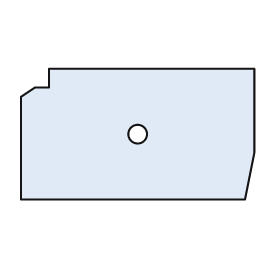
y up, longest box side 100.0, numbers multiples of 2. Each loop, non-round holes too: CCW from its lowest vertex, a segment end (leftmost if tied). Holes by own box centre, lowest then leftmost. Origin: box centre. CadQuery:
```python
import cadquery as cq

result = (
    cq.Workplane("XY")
    .moveTo(-50.0, -28.0)
    .lineTo(46.0, -28.0)
    .lineTo(50.0, -8.0)
    .lineTo(50.0, 28.0)
    .lineTo(-38.0, 28.0)
    .lineTo(-38.0, 20.0)
    .lineTo(-44.0, 20.0)
    .lineTo(-50.0, 16.0)
    .close()
    .moveTo(0.0, 0.0)
    .circle(4.0)
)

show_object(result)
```